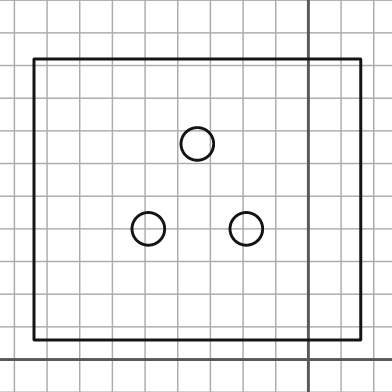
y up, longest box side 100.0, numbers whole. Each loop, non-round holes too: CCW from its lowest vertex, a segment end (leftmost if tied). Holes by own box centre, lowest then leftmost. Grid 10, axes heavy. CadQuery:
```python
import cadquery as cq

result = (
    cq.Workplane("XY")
    .moveTo(-84.0, 6.0)
    .lineTo(16.0, 6.0)
    .lineTo(16.0, 92.0)
    .lineTo(-84.0, 92.0)
    .close()
    .moveTo(-49.0, 40.0)
    .circle(5.0)
    .moveTo(-19.0, 40.0)
    .circle(5.0)
    .moveTo(-34.0, 66.0)
    .circle(5.0)
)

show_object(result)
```